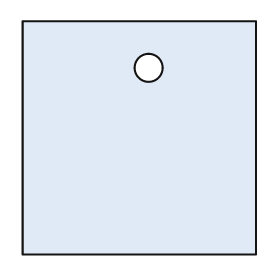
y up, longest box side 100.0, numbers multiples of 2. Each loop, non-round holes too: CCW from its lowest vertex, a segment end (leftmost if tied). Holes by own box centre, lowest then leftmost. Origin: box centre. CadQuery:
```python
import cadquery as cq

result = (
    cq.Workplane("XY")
    .moveTo(-50.0, -50.0)
    .lineTo(50.0, -50.0)
    .lineTo(50.0, 50.0)
    .lineTo(-50.0, 50.0)
    .close()
    .moveTo(4.0, 30.0)
    .circle(6.0)
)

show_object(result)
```